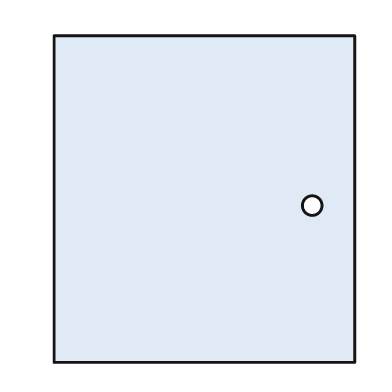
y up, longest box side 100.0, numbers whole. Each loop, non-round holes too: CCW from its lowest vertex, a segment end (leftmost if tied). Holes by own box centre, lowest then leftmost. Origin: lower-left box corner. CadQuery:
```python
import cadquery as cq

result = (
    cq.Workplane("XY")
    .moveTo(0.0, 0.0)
    .lineTo(92.0, 0.0)
    .lineTo(92.0, 100.0)
    .lineTo(0.0, 100.0)
    .close()
    .moveTo(79.0, 48.0)
    .circle(3.0)
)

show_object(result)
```